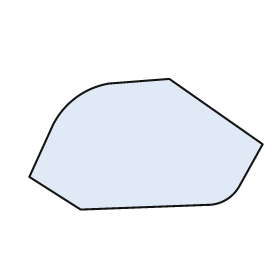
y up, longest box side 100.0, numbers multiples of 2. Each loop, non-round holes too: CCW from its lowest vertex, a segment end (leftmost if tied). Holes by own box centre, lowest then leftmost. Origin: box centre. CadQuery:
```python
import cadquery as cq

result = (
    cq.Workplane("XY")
    .moveTo(-28.0, -28.0)
    .lineTo(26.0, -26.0)
    .threePointArc((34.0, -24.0), (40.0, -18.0))
    .lineTo(50.0, 0.0)
    .lineTo(10.0, 28.0)
    .lineTo(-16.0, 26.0)
    .threePointArc((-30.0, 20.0), (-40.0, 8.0))
    .lineTo(-50.0, -14.0)
    .close()
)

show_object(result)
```